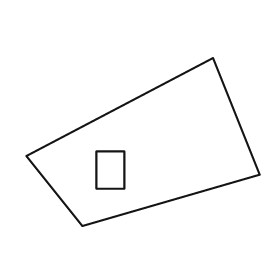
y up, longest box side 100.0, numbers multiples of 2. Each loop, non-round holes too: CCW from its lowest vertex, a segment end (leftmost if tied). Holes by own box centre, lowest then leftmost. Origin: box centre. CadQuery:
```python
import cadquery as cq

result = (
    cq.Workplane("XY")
    .moveTo(-26.0, -36.0)
    .lineTo(50.0, -14.0)
    .lineTo(30.0, 36.0)
    .lineTo(-50.0, -6.0)
    .close()
    .moveTo(-20.0, -20.0)
    .lineTo(-8.0, -20.0)
    .lineTo(-8.0, -4.0)
    .lineTo(-20.0, -4.0)
    .close()
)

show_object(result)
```